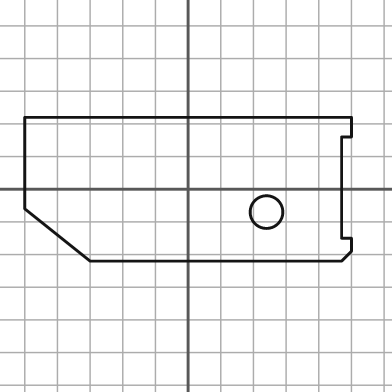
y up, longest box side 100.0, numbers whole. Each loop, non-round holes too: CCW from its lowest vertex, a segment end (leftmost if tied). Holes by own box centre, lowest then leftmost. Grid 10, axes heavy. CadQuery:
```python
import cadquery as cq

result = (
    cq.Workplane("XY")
    .moveTo(-30.0, -22.0)
    .lineTo(47.0, -22.0)
    .lineTo(50.0, -19.0)
    .lineTo(50.0, -15.0)
    .lineTo(47.0, -15.0)
    .lineTo(47.0, 16.0)
    .lineTo(50.0, 16.0)
    .lineTo(50.0, 22.0)
    .lineTo(-50.0, 22.0)
    .lineTo(-50.0, -6.0)
    .close()
    .moveTo(24.0, -7.0)
    .circle(5.0)
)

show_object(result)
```